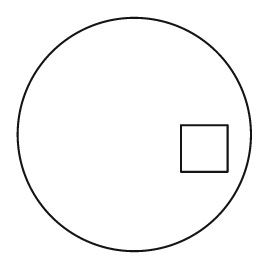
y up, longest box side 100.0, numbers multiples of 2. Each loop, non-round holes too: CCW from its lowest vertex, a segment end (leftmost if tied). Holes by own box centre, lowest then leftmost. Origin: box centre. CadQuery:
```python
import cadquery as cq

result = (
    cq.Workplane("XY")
    .moveTo(0.0, 0.0)
    .circle(50.0)
    .moveTo(20.0, -16.0)
    .lineTo(40.0, -16.0)
    .lineTo(40.0, 4.0)
    .lineTo(20.0, 4.0)
    .close()
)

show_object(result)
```